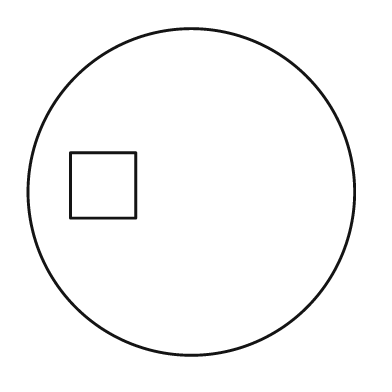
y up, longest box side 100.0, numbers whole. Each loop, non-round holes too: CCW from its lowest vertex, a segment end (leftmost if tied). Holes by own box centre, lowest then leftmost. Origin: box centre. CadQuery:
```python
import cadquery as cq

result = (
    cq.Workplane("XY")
    .moveTo(0.0, 0.0)
    .circle(50.0)
    .moveTo(-37.0, -8.0)
    .lineTo(-17.0, -8.0)
    .lineTo(-17.0, 12.0)
    .lineTo(-37.0, 12.0)
    .close()
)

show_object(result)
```